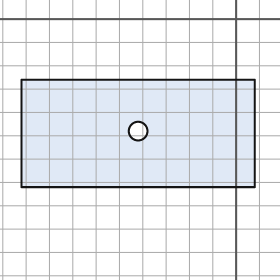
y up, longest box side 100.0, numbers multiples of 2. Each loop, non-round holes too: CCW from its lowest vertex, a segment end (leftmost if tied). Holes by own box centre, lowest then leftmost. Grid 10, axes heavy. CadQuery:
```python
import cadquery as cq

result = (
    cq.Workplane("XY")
    .moveTo(-92.0, -72.0)
    .lineTo(8.0, -72.0)
    .lineTo(8.0, -26.0)
    .lineTo(-92.0, -26.0)
    .close()
    .moveTo(-42.0, -48.0)
    .circle(4.0)
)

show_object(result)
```